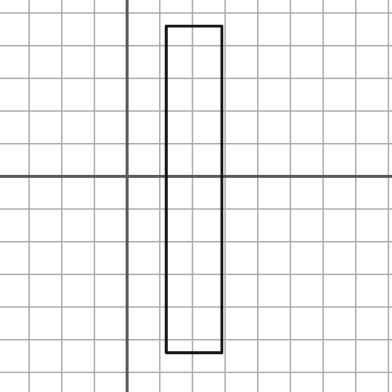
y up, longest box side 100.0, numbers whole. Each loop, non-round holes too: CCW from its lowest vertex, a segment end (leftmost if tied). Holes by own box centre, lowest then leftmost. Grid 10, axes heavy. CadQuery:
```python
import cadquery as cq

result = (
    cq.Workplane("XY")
    .moveTo(12.0, -54.0)
    .lineTo(29.0, -54.0)
    .lineTo(29.0, 46.0)
    .lineTo(12.0, 46.0)
    .close()
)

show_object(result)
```